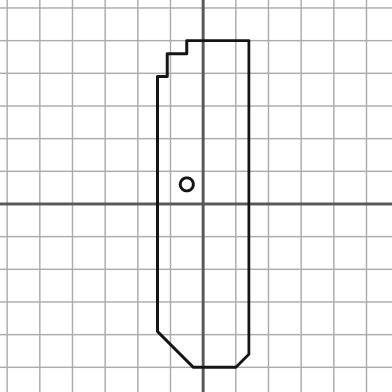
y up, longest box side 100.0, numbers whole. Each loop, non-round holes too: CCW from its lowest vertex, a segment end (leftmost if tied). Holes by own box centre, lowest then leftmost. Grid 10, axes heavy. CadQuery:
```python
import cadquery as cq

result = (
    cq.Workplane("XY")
    .moveTo(-3.0, -50.0)
    .lineTo(10.0, -50.0)
    .lineTo(14.0, -46.0)
    .lineTo(14.0, 50.0)
    .lineTo(-5.0, 50.0)
    .lineTo(-5.0, 46.0)
    .lineTo(-11.0, 46.0)
    .lineTo(-11.0, 39.0)
    .lineTo(-14.0, 39.0)
    .lineTo(-14.0, -39.0)
    .close()
    .moveTo(-5.0, 6.0)
    .circle(2.0)
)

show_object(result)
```